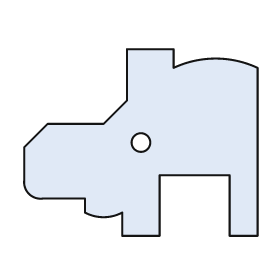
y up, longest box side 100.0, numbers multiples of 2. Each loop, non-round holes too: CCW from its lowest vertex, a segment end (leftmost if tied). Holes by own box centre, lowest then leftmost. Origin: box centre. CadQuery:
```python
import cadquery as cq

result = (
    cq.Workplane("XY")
    .moveTo(-8.0, -40.0)
    .lineTo(8.0, -40.0)
    .lineTo(8.0, -14.0)
    .lineTo(38.0, -14.0)
    .lineTo(38.0, -40.0)
    .lineTo(50.0, -40.0)
    .lineTo(50.0, 32.0)
    .threePointArc((32.0, 36.0), (14.0, 32.0))
    .lineTo(14.0, 40.0)
    .lineTo(-6.0, 40.0)
    .lineTo(-6.0, 18.0)
    .lineTo(-16.0, 8.0)
    .lineTo(-40.0, 8.0)
    .lineTo(-50.0, -2.0)
    .lineTo(-50.0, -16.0)
    .threePointArc((-48.0, -22.0), (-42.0, -24.0))
    .lineTo(-24.0, -24.0)
    .lineTo(-24.0, -30.0)
    .threePointArc((-16.0, -32.0), (-8.0, -30.0))
    .close()
    .moveTo(0.0, 0.0)
    .circle(4.0)
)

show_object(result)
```